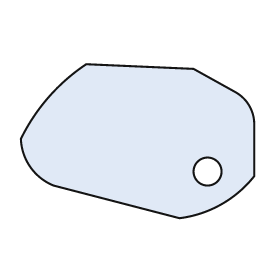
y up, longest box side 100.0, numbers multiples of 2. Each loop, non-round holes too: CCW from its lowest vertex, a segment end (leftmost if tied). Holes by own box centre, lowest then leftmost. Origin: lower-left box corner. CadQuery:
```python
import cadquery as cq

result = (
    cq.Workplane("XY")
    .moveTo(68.0, 0.0)
    .threePointArc((86.0, 6.0), (100.0, 18.0))
    .lineTo(100.0, 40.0)
    .threePointArc((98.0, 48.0), (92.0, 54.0))
    .lineTo(74.0, 64.0)
    .lineTo(28.0, 66.0)
    .threePointArc((12.0, 52.0), (0.0, 34.0))
    .threePointArc((4.0, 22.0), (14.0, 14.0))
    .close()
    .moveTo(80.0, 20.0)
    .circle(6.0)
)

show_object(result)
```